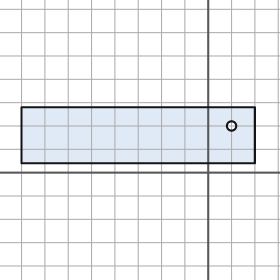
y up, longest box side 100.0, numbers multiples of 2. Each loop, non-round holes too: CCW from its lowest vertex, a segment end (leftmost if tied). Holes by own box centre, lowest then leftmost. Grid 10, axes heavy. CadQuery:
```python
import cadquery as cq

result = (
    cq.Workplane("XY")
    .moveTo(-80.0, 4.0)
    .lineTo(20.0, 4.0)
    .lineTo(20.0, 28.0)
    .lineTo(-80.0, 28.0)
    .close()
    .moveTo(10.0, 20.0)
    .circle(2.0)
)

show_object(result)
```